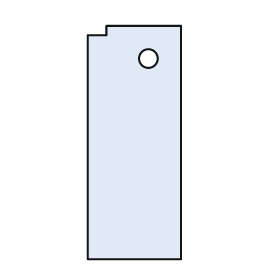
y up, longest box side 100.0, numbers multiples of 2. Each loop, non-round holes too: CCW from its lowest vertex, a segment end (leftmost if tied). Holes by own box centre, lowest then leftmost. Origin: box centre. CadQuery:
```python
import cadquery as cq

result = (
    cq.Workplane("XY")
    .moveTo(-20.0, -50.0)
    .lineTo(20.0, -50.0)
    .lineTo(20.0, 50.0)
    .lineTo(-12.0, 50.0)
    .lineTo(-12.0, 46.0)
    .lineTo(-20.0, 46.0)
    .close()
    .moveTo(6.0, 36.0)
    .circle(4.0)
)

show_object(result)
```